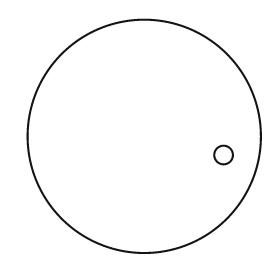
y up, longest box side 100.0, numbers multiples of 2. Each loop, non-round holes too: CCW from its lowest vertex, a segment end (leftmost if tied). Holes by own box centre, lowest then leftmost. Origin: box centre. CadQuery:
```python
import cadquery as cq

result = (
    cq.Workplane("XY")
    .moveTo(0.0, 0.0)
    .circle(50.0)
    .moveTo(34.0, -8.0)
    .circle(4.0)
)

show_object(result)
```